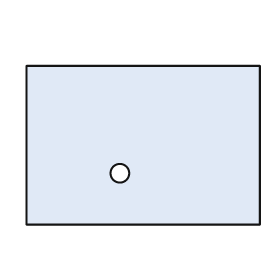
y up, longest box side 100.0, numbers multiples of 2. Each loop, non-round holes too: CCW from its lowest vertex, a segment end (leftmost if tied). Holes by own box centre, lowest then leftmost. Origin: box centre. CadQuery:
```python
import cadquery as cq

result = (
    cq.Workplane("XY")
    .moveTo(-50.0, -34.0)
    .lineTo(50.0, -34.0)
    .lineTo(50.0, 34.0)
    .lineTo(-50.0, 34.0)
    .close()
    .moveTo(-10.0, -12.0)
    .circle(4.0)
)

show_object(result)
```